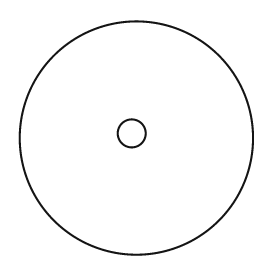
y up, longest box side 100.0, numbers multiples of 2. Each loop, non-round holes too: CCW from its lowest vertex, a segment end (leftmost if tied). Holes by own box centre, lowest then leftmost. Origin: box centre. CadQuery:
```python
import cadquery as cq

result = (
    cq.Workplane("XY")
    .moveTo(0.0, 0.0)
    .circle(50.0)
    .moveTo(-2.0, 2.0)
    .circle(6.0)
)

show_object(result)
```